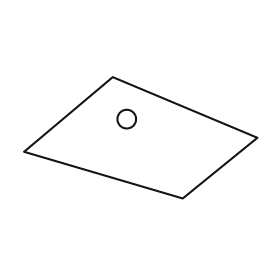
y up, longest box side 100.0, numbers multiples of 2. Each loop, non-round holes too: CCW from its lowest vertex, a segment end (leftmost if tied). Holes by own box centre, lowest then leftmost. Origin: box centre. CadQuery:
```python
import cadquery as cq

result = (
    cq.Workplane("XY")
    .moveTo(18.0, -26.0)
    .lineTo(50.0, 0.0)
    .lineTo(-12.0, 26.0)
    .lineTo(-50.0, -6.0)
    .close()
    .moveTo(-6.0, 8.0)
    .circle(4.0)
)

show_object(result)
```